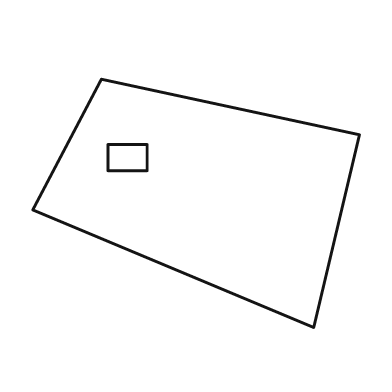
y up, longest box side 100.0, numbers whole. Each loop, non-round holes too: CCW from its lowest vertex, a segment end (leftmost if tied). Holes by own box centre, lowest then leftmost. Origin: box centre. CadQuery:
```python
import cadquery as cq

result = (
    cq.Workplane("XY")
    .moveTo(36.0, -38.0)
    .lineTo(50.0, 21.0)
    .lineTo(-29.0, 38.0)
    .lineTo(-50.0, -2.0)
    .close()
    .moveTo(-27.0, 10.0)
    .lineTo(-15.0, 10.0)
    .lineTo(-15.0, 18.0)
    .lineTo(-27.0, 18.0)
    .close()
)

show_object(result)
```